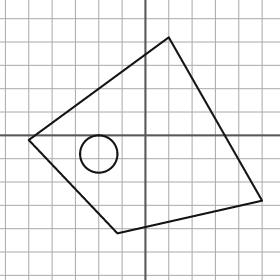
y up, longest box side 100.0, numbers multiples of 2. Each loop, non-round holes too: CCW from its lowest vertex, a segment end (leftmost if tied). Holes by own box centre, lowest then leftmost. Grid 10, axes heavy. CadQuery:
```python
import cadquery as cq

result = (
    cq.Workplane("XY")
    .moveTo(-12.0, -42.0)
    .lineTo(50.0, -28.0)
    .lineTo(10.0, 42.0)
    .lineTo(-50.0, -2.0)
    .close()
    .moveTo(-20.0, -8.0)
    .circle(8.0)
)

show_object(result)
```